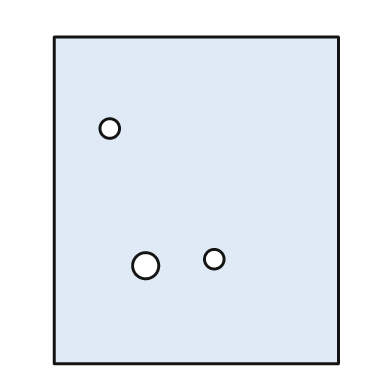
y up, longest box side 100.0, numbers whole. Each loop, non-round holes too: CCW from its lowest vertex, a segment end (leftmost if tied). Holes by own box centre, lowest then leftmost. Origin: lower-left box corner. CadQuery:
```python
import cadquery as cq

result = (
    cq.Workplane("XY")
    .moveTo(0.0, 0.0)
    .lineTo(87.0, 0.0)
    .lineTo(87.0, 100.0)
    .lineTo(0.0, 100.0)
    .close()
    .moveTo(28.0, 30.0)
    .circle(4.0)
    .moveTo(49.0, 32.0)
    .circle(3.0)
    .moveTo(17.0, 72.0)
    .circle(3.0)
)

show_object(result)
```